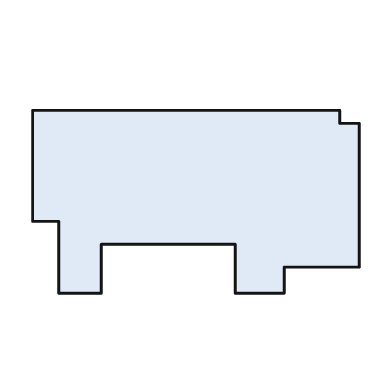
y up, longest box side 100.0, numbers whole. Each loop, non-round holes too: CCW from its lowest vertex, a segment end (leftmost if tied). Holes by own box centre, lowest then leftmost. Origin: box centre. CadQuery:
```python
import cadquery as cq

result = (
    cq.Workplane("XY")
    .moveTo(-42.0, -28.0)
    .lineTo(-29.0, -28.0)
    .lineTo(-29.0, -13.0)
    .lineTo(12.0, -13.0)
    .lineTo(12.0, -28.0)
    .lineTo(27.0, -28.0)
    .lineTo(27.0, -20.0)
    .lineTo(50.0, -20.0)
    .lineTo(50.0, 24.0)
    .lineTo(44.0, 24.0)
    .lineTo(44.0, 28.0)
    .lineTo(-50.0, 28.0)
    .lineTo(-50.0, -6.0)
    .lineTo(-42.0, -6.0)
    .close()
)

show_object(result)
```